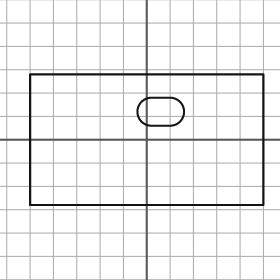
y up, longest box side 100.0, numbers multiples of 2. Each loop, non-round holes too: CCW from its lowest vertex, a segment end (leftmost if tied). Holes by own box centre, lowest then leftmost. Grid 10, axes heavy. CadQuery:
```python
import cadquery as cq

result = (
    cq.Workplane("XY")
    .moveTo(-50.0, -28.0)
    .lineTo(50.0, -28.0)
    .lineTo(50.0, 28.0)
    .lineTo(-50.0, 28.0)
    .close()
    .moveTo(2.0, 6.0)
    .lineTo(10.0, 6.0)
    .threePointArc((16.0, 12.0), (10.0, 18.0))
    .lineTo(2.0, 18.0)
    .threePointArc((-4.0, 12.0), (2.0, 6.0))
    .close()
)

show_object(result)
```